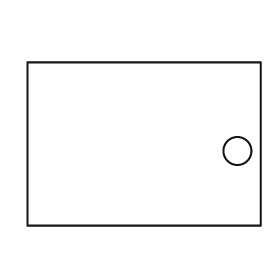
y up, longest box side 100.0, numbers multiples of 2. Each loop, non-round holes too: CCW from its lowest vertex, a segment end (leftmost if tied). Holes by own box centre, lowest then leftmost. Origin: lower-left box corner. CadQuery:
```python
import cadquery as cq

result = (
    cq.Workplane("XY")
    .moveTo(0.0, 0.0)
    .lineTo(100.0, 0.0)
    .lineTo(100.0, 70.0)
    .lineTo(0.0, 70.0)
    .close()
    .moveTo(90.0, 32.0)
    .circle(6.0)
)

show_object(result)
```